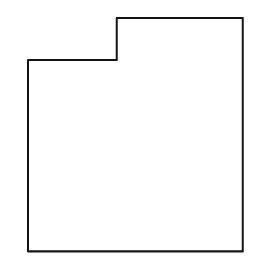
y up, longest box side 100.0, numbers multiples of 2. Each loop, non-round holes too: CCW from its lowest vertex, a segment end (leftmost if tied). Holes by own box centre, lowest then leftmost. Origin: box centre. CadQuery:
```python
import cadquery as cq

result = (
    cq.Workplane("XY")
    .moveTo(-46.0, -50.0)
    .lineTo(46.0, -50.0)
    .lineTo(46.0, 50.0)
    .lineTo(-8.0, 50.0)
    .lineTo(-8.0, 32.0)
    .lineTo(-46.0, 32.0)
    .close()
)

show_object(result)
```